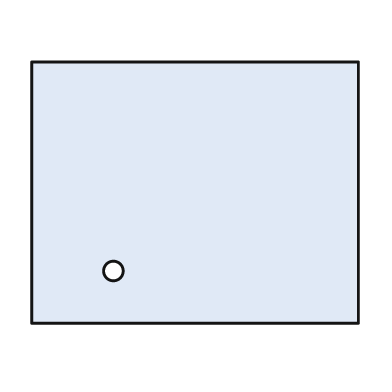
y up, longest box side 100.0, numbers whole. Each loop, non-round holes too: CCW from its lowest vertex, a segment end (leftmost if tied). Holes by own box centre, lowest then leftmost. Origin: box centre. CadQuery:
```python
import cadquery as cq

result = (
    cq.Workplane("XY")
    .moveTo(-50.0, -40.0)
    .lineTo(50.0, -40.0)
    .lineTo(50.0, 40.0)
    .lineTo(-50.0, 40.0)
    .close()
    .moveTo(-25.0, -24.0)
    .circle(3.0)
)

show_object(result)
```